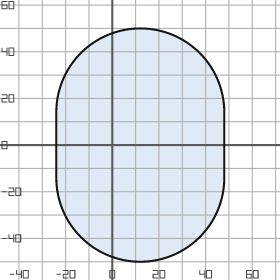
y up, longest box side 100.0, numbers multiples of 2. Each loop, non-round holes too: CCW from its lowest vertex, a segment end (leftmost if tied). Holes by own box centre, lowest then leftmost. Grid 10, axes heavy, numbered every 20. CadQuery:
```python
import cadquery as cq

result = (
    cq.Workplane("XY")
    .moveTo(-24.0, -14.0)
    .threePointArc((12.0, -50.0), (48.0, -14.0))
    .lineTo(48.0, 14.0)
    .threePointArc((12.0, 50.0), (-24.0, 14.0))
    .close()
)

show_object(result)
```